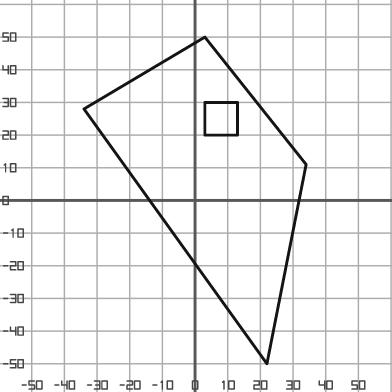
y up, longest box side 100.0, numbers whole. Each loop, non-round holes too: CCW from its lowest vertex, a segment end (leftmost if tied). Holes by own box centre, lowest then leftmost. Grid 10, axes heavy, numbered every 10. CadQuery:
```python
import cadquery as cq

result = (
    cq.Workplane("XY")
    .moveTo(22.0, -50.0)
    .lineTo(34.0, 11.0)
    .lineTo(3.0, 50.0)
    .lineTo(-34.0, 28.0)
    .close()
    .moveTo(3.0, 20.0)
    .lineTo(13.0, 20.0)
    .lineTo(13.0, 30.0)
    .lineTo(3.0, 30.0)
    .close()
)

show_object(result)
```